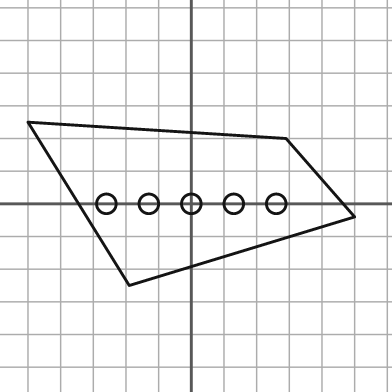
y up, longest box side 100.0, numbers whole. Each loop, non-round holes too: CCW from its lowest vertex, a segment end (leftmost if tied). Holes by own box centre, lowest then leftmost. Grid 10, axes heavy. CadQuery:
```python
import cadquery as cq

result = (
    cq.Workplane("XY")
    .moveTo(-19.0, -25.0)
    .lineTo(50.0, -4.0)
    .lineTo(29.0, 20.0)
    .lineTo(-50.0, 25.0)
    .close()
    .moveTo(-26.0, 0.0)
    .circle(3.0)
    .moveTo(-13.0, 0.0)
    .circle(3.0)
    .moveTo(0.0, 0.0)
    .circle(3.0)
    .moveTo(13.0, 0.0)
    .circle(3.0)
    .moveTo(26.0, 0.0)
    .circle(3.0)
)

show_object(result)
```